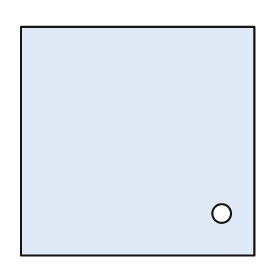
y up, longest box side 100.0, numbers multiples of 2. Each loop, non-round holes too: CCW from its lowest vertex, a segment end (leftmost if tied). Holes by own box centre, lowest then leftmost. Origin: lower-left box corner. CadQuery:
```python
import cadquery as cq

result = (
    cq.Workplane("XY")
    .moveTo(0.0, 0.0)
    .lineTo(100.0, 0.0)
    .lineTo(100.0, 98.0)
    .lineTo(0.0, 98.0)
    .close()
    .moveTo(86.0, 18.0)
    .circle(4.0)
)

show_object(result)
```